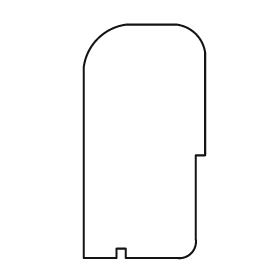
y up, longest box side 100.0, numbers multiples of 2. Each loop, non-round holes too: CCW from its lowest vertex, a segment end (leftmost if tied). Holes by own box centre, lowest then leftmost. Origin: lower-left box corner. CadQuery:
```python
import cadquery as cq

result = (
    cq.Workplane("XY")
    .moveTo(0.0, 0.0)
    .lineTo(14.0, 0.0)
    .lineTo(14.0, 4.0)
    .lineTo(18.0, 4.0)
    .lineTo(18.0, 0.0)
    .lineTo(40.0, 0.0)
    .threePointArc((46.0, 2.0), (48.0, 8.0))
    .lineTo(48.0, 44.0)
    .lineTo(52.0, 44.0)
    .lineTo(52.0, 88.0)
    .threePointArc((48.0, 96.0), (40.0, 100.0))
    .lineTo(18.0, 100.0)
    .threePointArc((6.0, 94.0), (0.0, 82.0))
    .close()
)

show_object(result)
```